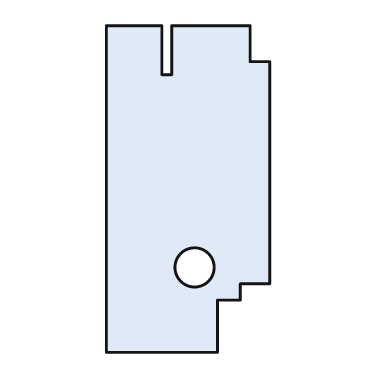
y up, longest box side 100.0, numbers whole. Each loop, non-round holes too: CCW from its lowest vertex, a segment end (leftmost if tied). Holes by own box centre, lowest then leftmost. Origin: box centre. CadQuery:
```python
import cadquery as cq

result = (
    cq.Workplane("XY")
    .moveTo(-25.0, -50.0)
    .lineTo(9.0, -50.0)
    .lineTo(9.0, -34.0)
    .lineTo(16.0, -34.0)
    .lineTo(16.0, -29.0)
    .lineTo(25.0, -29.0)
    .lineTo(25.0, 39.0)
    .lineTo(19.0, 39.0)
    .lineTo(19.0, 50.0)
    .lineTo(-5.0, 50.0)
    .lineTo(-5.0, 35.0)
    .lineTo(-8.0, 35.0)
    .lineTo(-8.0, 50.0)
    .lineTo(-25.0, 50.0)
    .close()
    .moveTo(2.0, -24.0)
    .circle(6.0)
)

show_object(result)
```